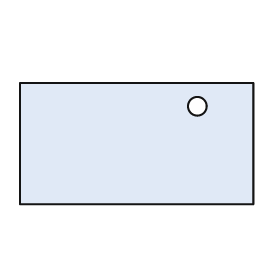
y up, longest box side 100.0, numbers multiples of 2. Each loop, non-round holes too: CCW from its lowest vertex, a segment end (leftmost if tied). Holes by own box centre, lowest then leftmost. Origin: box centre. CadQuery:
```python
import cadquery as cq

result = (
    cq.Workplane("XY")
    .moveTo(-50.0, -26.0)
    .lineTo(50.0, -26.0)
    .lineTo(50.0, 26.0)
    .lineTo(-50.0, 26.0)
    .close()
    .moveTo(26.0, 16.0)
    .circle(4.0)
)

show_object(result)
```